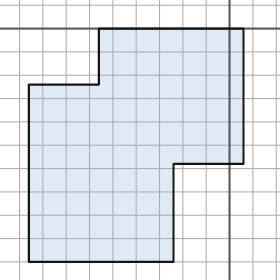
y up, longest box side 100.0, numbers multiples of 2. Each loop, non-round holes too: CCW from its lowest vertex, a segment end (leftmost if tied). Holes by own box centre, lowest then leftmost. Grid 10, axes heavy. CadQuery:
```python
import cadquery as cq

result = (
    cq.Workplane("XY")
    .moveTo(-86.0, -100.0)
    .lineTo(-24.0, -100.0)
    .lineTo(-24.0, -58.0)
    .lineTo(6.0, -58.0)
    .lineTo(6.0, 0.0)
    .lineTo(-56.0, 0.0)
    .lineTo(-56.0, -24.0)
    .lineTo(-86.0, -24.0)
    .close()
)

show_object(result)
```